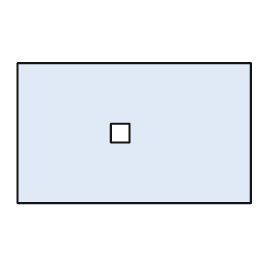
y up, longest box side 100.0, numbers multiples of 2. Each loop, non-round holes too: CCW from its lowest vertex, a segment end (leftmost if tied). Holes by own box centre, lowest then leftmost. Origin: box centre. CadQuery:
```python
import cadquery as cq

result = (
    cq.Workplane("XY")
    .moveTo(-50.0, -30.0)
    .lineTo(50.0, -30.0)
    .lineTo(50.0, 30.0)
    .lineTo(-50.0, 30.0)
    .close()
    .moveTo(-10.0, -4.0)
    .lineTo(-2.0, -4.0)
    .lineTo(-2.0, 4.0)
    .lineTo(-10.0, 4.0)
    .close()
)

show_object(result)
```